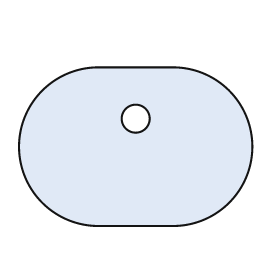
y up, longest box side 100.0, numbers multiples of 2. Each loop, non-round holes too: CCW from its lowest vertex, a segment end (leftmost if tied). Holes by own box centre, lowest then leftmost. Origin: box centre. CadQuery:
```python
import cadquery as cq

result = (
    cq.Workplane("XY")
    .moveTo(-16.0, -34.0)
    .lineTo(16.0, -34.0)
    .threePointArc((50.0, 0.0), (16.0, 34.0))
    .lineTo(-16.0, 34.0)
    .threePointArc((-50.0, 0.0), (-16.0, -34.0))
    .close()
    .moveTo(0.0, 12.0)
    .circle(6.0)
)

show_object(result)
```